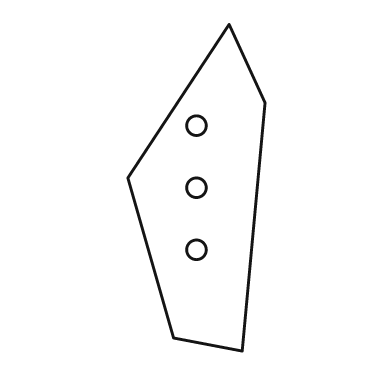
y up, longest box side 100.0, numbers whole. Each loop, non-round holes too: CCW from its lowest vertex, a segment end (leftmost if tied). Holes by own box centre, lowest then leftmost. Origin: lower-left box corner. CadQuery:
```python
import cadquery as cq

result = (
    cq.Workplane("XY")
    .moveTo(35.0, 0.0)
    .lineTo(42.0, 76.0)
    .lineTo(31.0, 100.0)
    .lineTo(0.0, 53.0)
    .lineTo(14.0, 4.0)
    .close()
    .moveTo(21.0, 31.0)
    .circle(3.0)
    .moveTo(21.0, 50.0)
    .circle(3.0)
    .moveTo(21.0, 69.0)
    .circle(3.0)
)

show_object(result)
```